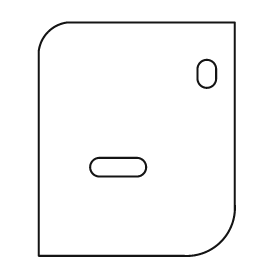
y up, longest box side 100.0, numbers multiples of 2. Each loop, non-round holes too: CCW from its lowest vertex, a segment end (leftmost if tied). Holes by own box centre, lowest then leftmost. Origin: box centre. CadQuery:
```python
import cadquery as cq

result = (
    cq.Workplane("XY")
    .moveTo(-42.0, -50.0)
    .lineTo(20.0, -50.0)
    .threePointArc((36.0, -44.0), (42.0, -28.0))
    .lineTo(42.0, 50.0)
    .lineTo(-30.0, 50.0)
    .threePointArc((-38.0, 46.0), (-42.0, 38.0))
    .close()
    .moveTo(-16.0, -16.0)
    .lineTo(0.0, -16.0)
    .threePointArc((4.0, -12.0), (0.0, -8.0))
    .lineTo(-16.0, -8.0)
    .threePointArc((-20.0, -12.0), (-16.0, -16.0))
    .close()
    .moveTo(26.0, 26.0)
    .threePointArc((30.0, 22.0), (34.0, 26.0))
    .lineTo(34.0, 30.0)
    .threePointArc((30.0, 34.0), (26.0, 30.0))
    .close()
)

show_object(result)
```